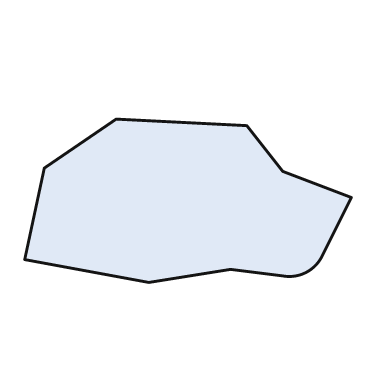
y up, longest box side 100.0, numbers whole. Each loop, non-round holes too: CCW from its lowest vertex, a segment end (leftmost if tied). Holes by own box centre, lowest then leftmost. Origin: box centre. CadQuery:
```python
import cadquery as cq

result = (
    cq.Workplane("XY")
    .moveTo(-12.0, -25.0)
    .lineTo(13.0, -21.0)
    .lineTo(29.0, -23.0)
    .threePointArc((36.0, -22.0), (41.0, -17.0))
    .lineTo(50.0, 1.0)
    .lineTo(29.0, 9.0)
    .lineTo(18.0, 23.0)
    .lineTo(-22.0, 25.0)
    .lineTo(-44.0, 10.0)
    .lineTo(-50.0, -18.0)
    .close()
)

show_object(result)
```